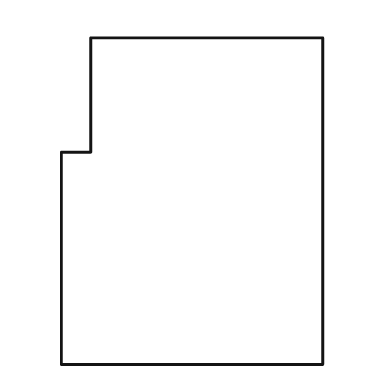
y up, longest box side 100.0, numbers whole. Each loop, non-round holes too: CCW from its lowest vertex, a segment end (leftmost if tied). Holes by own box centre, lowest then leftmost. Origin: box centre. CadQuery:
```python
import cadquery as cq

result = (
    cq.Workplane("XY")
    .moveTo(-40.0, -50.0)
    .lineTo(40.0, -50.0)
    .lineTo(40.0, 50.0)
    .lineTo(-31.0, 50.0)
    .lineTo(-31.0, 15.0)
    .lineTo(-40.0, 15.0)
    .close()
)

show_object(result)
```